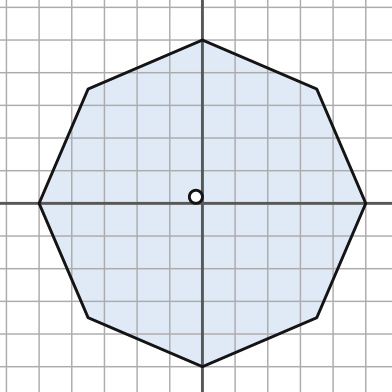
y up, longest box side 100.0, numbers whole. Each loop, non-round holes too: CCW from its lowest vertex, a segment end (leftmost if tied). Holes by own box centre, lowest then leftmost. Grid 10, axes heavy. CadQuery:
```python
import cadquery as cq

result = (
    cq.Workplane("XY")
    .moveTo(0.0, -50.0)
    .lineTo(35.0, -35.0)
    .lineTo(50.0, 0.0)
    .lineTo(35.0, 35.0)
    .lineTo(0.0, 50.0)
    .lineTo(-35.0, 35.0)
    .lineTo(-50.0, 0.0)
    .lineTo(-35.0, -35.0)
    .close()
    .moveTo(-2.0, 2.0)
    .circle(2.0)
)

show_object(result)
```